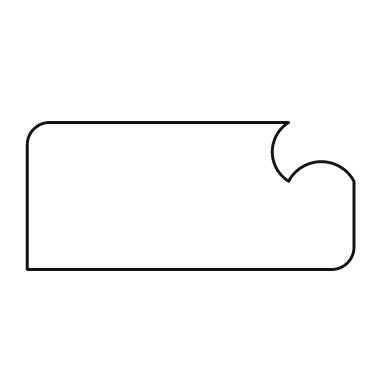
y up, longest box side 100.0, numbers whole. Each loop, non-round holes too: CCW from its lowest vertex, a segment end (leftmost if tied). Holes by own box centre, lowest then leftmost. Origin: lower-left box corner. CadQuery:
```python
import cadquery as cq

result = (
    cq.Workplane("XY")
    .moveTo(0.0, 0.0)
    .lineTo(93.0, 0.0)
    .threePointArc((98.0, 2.0), (100.0, 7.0))
    .lineTo(100.0, 27.0)
    .threePointArc((90.0, 33.0), (80.0, 27.0))
    .threePointArc((75.0, 36.0), (80.0, 45.0))
    .lineTo(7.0, 45.0)
    .threePointArc((2.0, 43.0), (0.0, 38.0))
    .close()
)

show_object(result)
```